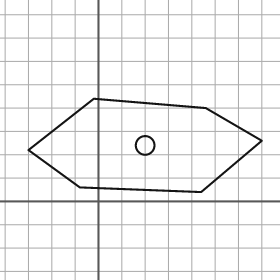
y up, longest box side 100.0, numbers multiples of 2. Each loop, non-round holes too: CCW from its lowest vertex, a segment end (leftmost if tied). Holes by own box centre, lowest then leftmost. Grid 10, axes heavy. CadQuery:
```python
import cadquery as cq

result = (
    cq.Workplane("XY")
    .moveTo(44.0, 4.0)
    .lineTo(70.0, 26.0)
    .lineTo(46.0, 40.0)
    .lineTo(-2.0, 44.0)
    .lineTo(-30.0, 22.0)
    .lineTo(-8.0, 6.0)
    .close()
    .moveTo(20.0, 24.0)
    .circle(4.0)
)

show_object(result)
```